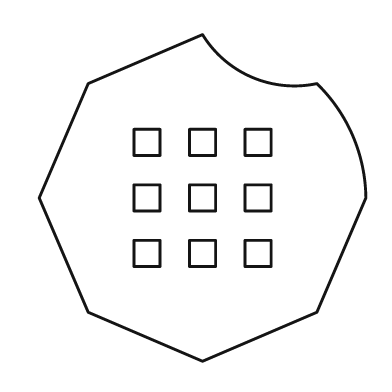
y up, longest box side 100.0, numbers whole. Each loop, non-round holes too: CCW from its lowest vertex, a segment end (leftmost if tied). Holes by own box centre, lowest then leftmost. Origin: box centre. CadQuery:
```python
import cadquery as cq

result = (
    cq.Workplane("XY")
    .moveTo(0.0, -50.0)
    .lineTo(35.0, -35.0)
    .lineTo(50.0, 0.0)
    .threePointArc((46.0, 19.0), (35.0, 35.0))
    .threePointArc((15.0, 37.0), (0.0, 50.0))
    .lineTo(-35.0, 35.0)
    .lineTo(-50.0, 0.0)
    .lineTo(-35.0, -35.0)
    .close()
    .moveTo(-21.0, -21.0)
    .lineTo(-13.0, -21.0)
    .lineTo(-13.0, -13.0)
    .lineTo(-21.0, -13.0)
    .close()
    .moveTo(-4.0, -21.0)
    .lineTo(4.0, -21.0)
    .lineTo(4.0, -13.0)
    .lineTo(-4.0, -13.0)
    .close()
    .moveTo(13.0, -21.0)
    .lineTo(21.0, -21.0)
    .lineTo(21.0, -13.0)
    .lineTo(13.0, -13.0)
    .close()
    .moveTo(-21.0, -4.0)
    .lineTo(-13.0, -4.0)
    .lineTo(-13.0, 4.0)
    .lineTo(-21.0, 4.0)
    .close()
    .moveTo(-4.0, -4.0)
    .lineTo(4.0, -4.0)
    .lineTo(4.0, 4.0)
    .lineTo(-4.0, 4.0)
    .close()
    .moveTo(13.0, -4.0)
    .lineTo(21.0, -4.0)
    .lineTo(21.0, 4.0)
    .lineTo(13.0, 4.0)
    .close()
    .moveTo(-21.0, 13.0)
    .lineTo(-13.0, 13.0)
    .lineTo(-13.0, 21.0)
    .lineTo(-21.0, 21.0)
    .close()
    .moveTo(-4.0, 13.0)
    .lineTo(4.0, 13.0)
    .lineTo(4.0, 21.0)
    .lineTo(-4.0, 21.0)
    .close()
    .moveTo(13.0, 13.0)
    .lineTo(21.0, 13.0)
    .lineTo(21.0, 21.0)
    .lineTo(13.0, 21.0)
    .close()
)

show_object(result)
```